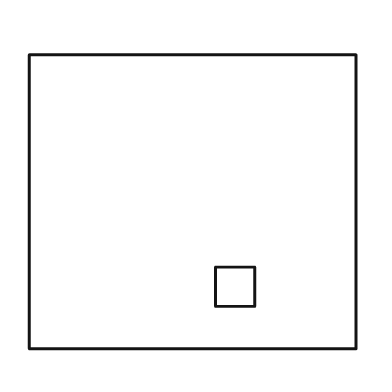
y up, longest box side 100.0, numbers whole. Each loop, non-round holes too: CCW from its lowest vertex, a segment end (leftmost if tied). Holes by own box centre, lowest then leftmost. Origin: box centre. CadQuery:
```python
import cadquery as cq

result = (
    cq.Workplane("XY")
    .moveTo(-50.0, -45.0)
    .lineTo(50.0, -45.0)
    .lineTo(50.0, 45.0)
    .lineTo(-50.0, 45.0)
    .close()
    .moveTo(7.0, -32.0)
    .lineTo(19.0, -32.0)
    .lineTo(19.0, -20.0)
    .lineTo(7.0, -20.0)
    .close()
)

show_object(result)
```